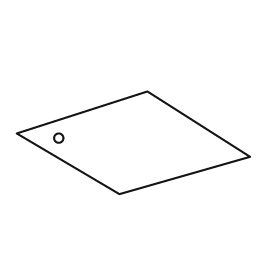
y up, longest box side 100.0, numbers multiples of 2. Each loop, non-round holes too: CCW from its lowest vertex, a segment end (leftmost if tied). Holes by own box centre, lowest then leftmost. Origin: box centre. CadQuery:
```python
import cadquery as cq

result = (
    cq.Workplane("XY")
    .moveTo(-6.0, -22.0)
    .lineTo(50.0, -6.0)
    .lineTo(6.0, 22.0)
    .lineTo(-50.0, 4.0)
    .close()
    .moveTo(-32.0, 2.0)
    .circle(2.0)
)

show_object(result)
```